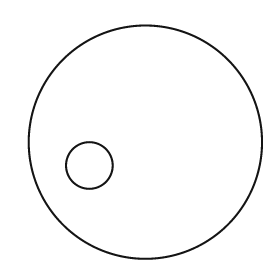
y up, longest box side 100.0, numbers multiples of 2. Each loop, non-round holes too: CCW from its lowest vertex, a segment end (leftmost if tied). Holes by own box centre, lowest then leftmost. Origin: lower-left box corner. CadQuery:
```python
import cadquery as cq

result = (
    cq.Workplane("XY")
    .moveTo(50.0, 50.0)
    .circle(50.0)
    .moveTo(26.0, 40.0)
    .circle(10.0)
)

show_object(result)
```